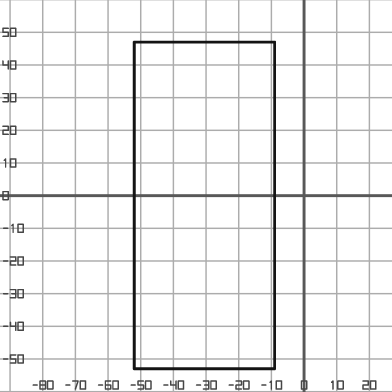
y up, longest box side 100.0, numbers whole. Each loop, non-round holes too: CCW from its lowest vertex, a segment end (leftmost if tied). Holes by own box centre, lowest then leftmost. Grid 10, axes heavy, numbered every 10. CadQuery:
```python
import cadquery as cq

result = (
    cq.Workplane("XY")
    .moveTo(-52.0, -53.0)
    .lineTo(-9.0, -53.0)
    .lineTo(-9.0, 47.0)
    .lineTo(-52.0, 47.0)
    .close()
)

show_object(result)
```